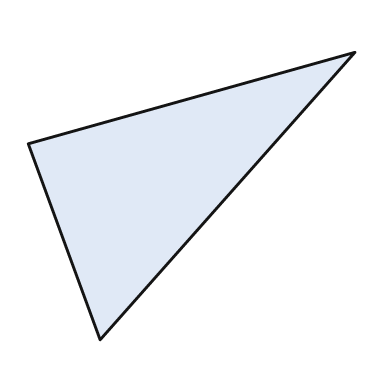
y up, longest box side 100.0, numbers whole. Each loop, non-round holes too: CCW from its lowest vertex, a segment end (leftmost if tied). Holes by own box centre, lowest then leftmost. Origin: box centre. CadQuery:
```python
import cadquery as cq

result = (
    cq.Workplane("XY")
    .moveTo(-28.0, -44.0)
    .lineTo(50.0, 44.0)
    .lineTo(-50.0, 16.0)
    .close()
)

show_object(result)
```